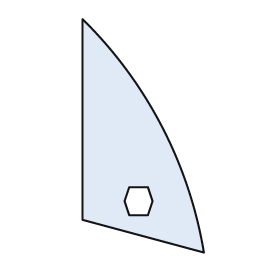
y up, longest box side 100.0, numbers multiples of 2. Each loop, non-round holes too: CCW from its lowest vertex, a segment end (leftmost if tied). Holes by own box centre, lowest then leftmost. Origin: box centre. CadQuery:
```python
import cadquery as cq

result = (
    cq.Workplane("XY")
    .moveTo(26.0, -50.0)
    .threePointArc((8.0, 4.0), (-26.0, 50.0))
    .lineTo(-26.0, -36.0)
    .close()
    .moveTo(-6.0, -34.0)
    .lineTo(2.0, -34.0)
    .lineTo(4.0, -28.0)
    .lineTo(2.0, -22.0)
    .lineTo(-6.0, -22.0)
    .lineTo(-8.0, -28.0)
    .close()
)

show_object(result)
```